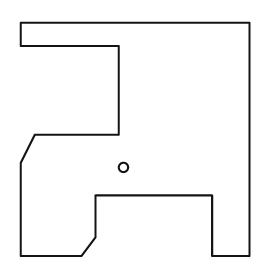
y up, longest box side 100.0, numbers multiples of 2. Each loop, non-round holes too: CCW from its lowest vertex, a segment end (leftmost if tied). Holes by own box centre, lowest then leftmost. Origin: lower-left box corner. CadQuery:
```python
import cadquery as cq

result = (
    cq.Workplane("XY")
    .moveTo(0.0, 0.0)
    .lineTo(26.0, 0.0)
    .lineTo(32.0, 8.0)
    .lineTo(32.0, 26.0)
    .lineTo(82.0, 26.0)
    .lineTo(82.0, 0.0)
    .lineTo(98.0, 0.0)
    .lineTo(98.0, 100.0)
    .lineTo(0.0, 100.0)
    .lineTo(0.0, 90.0)
    .lineTo(42.0, 90.0)
    .lineTo(42.0, 52.0)
    .lineTo(6.0, 52.0)
    .lineTo(0.0, 40.0)
    .close()
    .moveTo(44.0, 38.0)
    .circle(2.0)
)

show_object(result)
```